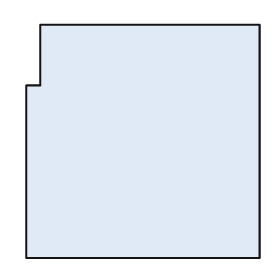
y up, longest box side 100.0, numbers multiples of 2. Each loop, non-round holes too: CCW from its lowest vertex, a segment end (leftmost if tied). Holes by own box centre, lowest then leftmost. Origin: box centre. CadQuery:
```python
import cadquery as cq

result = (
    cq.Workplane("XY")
    .moveTo(-50.0, -50.0)
    .lineTo(50.0, -50.0)
    .lineTo(50.0, 50.0)
    .lineTo(-44.0, 50.0)
    .lineTo(-44.0, 24.0)
    .lineTo(-50.0, 24.0)
    .close()
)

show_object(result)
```